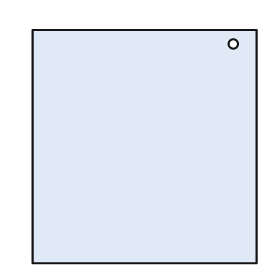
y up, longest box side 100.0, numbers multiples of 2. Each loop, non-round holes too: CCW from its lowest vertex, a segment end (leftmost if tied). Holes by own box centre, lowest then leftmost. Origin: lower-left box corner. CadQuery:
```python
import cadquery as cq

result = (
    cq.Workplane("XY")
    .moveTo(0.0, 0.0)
    .lineTo(96.0, 0.0)
    .lineTo(96.0, 100.0)
    .lineTo(0.0, 100.0)
    .close()
    .moveTo(86.0, 94.0)
    .circle(2.0)
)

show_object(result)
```